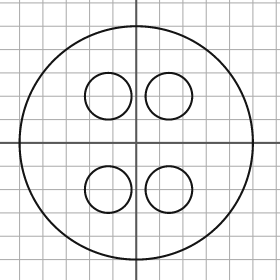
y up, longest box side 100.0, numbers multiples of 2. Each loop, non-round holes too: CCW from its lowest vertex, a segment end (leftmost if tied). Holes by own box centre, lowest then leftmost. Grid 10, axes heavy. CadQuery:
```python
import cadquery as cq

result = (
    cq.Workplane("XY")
    .moveTo(0.0, 0.0)
    .circle(50.0)
    .moveTo(-12.0, -20.0)
    .circle(10.0)
    .moveTo(14.0, -20.0)
    .circle(10.0)
    .moveTo(-12.0, 20.0)
    .circle(10.0)
    .moveTo(14.0, 20.0)
    .circle(10.0)
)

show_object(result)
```